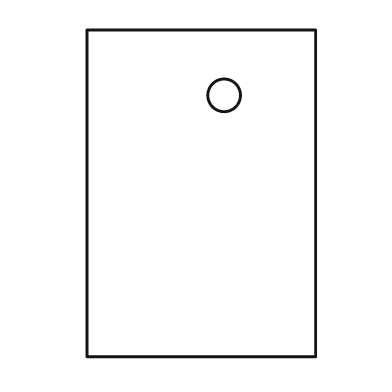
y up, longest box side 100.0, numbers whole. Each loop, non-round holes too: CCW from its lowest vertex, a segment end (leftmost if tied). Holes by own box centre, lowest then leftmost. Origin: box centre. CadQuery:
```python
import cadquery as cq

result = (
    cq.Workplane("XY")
    .moveTo(-35.0, -50.0)
    .lineTo(35.0, -50.0)
    .lineTo(35.0, 50.0)
    .lineTo(-35.0, 50.0)
    .close()
    .moveTo(7.0, 30.0)
    .circle(5.0)
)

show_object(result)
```